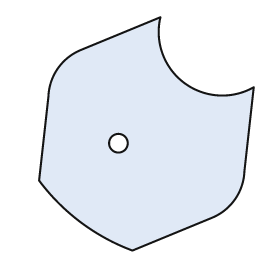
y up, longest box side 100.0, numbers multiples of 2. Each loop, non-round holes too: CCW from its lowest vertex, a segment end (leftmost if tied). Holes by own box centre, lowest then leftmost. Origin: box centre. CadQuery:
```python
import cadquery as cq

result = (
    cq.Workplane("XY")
    .moveTo(-6.0, -50.0)
    .lineTo(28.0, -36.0)
    .threePointArc((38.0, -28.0), (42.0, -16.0))
    .lineTo(46.0, 20.0)
    .threePointArc((16.0, 22.0), (6.0, 50.0))
    .lineTo(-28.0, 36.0)
    .threePointArc((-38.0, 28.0), (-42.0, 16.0))
    .lineTo(-46.0, -20.0)
    .threePointArc((-28.0, -38.0), (-6.0, -50.0))
    .close()
    .moveTo(-12.0, -4.0)
    .circle(4.0)
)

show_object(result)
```